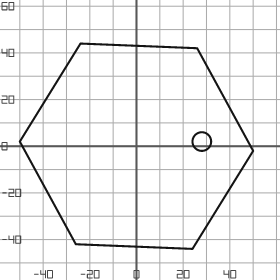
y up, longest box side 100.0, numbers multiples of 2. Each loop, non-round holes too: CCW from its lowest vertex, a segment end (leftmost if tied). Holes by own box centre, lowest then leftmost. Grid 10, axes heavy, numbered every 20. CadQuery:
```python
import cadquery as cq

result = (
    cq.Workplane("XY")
    .moveTo(24.0, -44.0)
    .lineTo(50.0, -2.0)
    .lineTo(26.0, 42.0)
    .lineTo(-24.0, 44.0)
    .lineTo(-50.0, 2.0)
    .lineTo(-26.0, -42.0)
    .close()
    .moveTo(28.0, 2.0)
    .circle(4.0)
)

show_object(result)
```